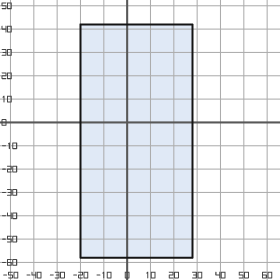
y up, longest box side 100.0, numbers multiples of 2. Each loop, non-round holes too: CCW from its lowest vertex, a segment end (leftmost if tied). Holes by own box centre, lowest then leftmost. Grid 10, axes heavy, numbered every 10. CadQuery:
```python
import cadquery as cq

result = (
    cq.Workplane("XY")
    .moveTo(-20.0, -58.0)
    .lineTo(28.0, -58.0)
    .lineTo(28.0, 42.0)
    .lineTo(-20.0, 42.0)
    .close()
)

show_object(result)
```